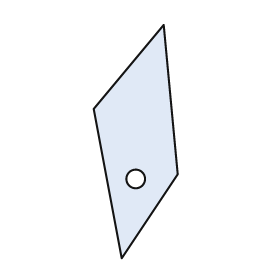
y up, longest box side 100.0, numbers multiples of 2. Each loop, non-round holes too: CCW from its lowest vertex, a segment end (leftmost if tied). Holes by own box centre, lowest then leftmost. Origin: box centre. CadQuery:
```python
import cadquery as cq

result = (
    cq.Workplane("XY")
    .moveTo(-6.0, -50.0)
    .lineTo(18.0, -14.0)
    .lineTo(12.0, 50.0)
    .lineTo(-18.0, 14.0)
    .close()
    .moveTo(0.0, -16.0)
    .circle(4.0)
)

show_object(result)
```